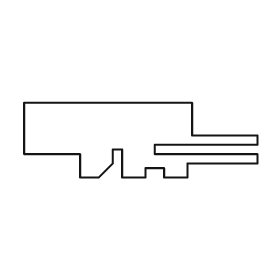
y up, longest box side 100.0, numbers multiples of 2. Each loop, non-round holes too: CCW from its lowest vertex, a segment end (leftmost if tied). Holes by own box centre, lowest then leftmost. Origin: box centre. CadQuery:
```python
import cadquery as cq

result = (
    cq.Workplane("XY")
    .moveTo(-26.0, -16.0)
    .lineTo(-18.0, -16.0)
    .lineTo(-12.0, -10.0)
    .lineTo(-12.0, -4.0)
    .lineTo(-8.0, -4.0)
    .lineTo(-8.0, -16.0)
    .lineTo(2.0, -16.0)
    .lineTo(2.0, -12.0)
    .lineTo(10.0, -12.0)
    .lineTo(10.0, -16.0)
    .lineTo(20.0, -16.0)
    .lineTo(20.0, -10.0)
    .lineTo(50.0, -10.0)
    .lineTo(50.0, -6.0)
    .lineTo(6.0, -6.0)
    .lineTo(6.0, -2.0)
    .lineTo(50.0, -2.0)
    .lineTo(50.0, 2.0)
    .lineTo(22.0, 2.0)
    .lineTo(22.0, 16.0)
    .lineTo(-50.0, 16.0)
    .lineTo(-50.0, -6.0)
    .lineTo(-26.0, -6.0)
    .close()
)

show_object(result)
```